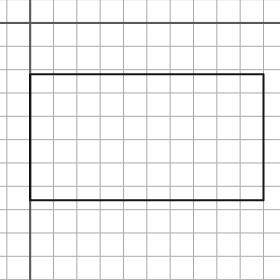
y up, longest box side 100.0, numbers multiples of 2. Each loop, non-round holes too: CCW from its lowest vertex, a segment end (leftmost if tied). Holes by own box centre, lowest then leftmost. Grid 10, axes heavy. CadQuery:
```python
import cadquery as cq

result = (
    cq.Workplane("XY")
    .moveTo(0.0, -76.0)
    .lineTo(100.0, -76.0)
    .lineTo(100.0, -22.0)
    .lineTo(0.0, -22.0)
    .close()
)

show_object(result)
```